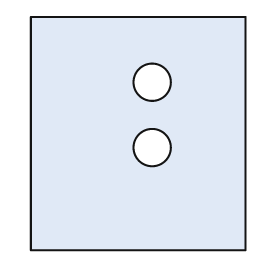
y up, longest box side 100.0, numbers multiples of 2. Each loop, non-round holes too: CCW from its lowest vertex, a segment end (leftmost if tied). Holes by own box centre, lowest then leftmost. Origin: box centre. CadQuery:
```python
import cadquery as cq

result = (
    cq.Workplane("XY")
    .moveTo(-46.0, -50.0)
    .lineTo(46.0, -50.0)
    .lineTo(46.0, 50.0)
    .lineTo(-46.0, 50.0)
    .close()
    .moveTo(6.0, -6.0)
    .circle(8.0)
    .moveTo(6.0, 22.0)
    .circle(8.0)
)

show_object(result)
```